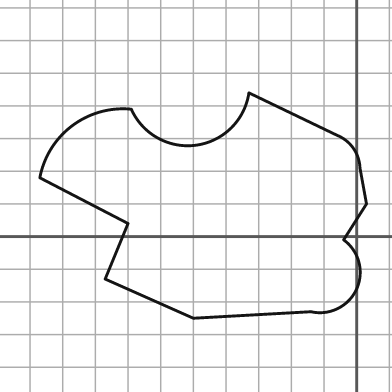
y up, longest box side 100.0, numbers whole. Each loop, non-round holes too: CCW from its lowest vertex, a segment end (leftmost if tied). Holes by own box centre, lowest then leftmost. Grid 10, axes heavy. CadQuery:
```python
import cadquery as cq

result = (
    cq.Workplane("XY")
    .moveTo(-50.0, -25.0)
    .lineTo(-14.0, -23.0)
    .threePointArc((0.0, -16.0), (-4.0, -1.0))
    .lineTo(3.0, 10.0)
    .lineTo(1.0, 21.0)
    .threePointArc((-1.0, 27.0), (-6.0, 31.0))
    .lineTo(-33.0, 44.0)
    .threePointArc((-49.0, 28.0), (-69.0, 39.0))
    .threePointArc((-87.0, 34.0), (-97.0, 18.0))
    .lineTo(-70.0, 4.0)
    .lineTo(-77.0, -13.0)
    .close()
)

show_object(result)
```